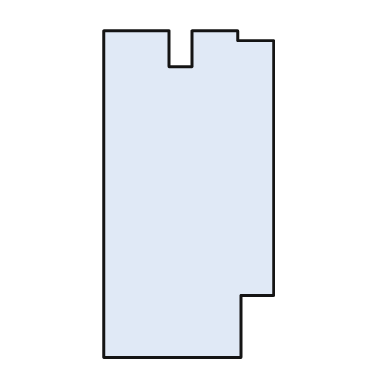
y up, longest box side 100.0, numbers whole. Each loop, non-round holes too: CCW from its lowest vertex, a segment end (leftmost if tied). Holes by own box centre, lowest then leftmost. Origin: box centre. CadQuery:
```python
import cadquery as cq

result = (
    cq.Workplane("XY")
    .moveTo(-26.0, -50.0)
    .lineTo(16.0, -50.0)
    .lineTo(16.0, -31.0)
    .lineTo(26.0, -31.0)
    .lineTo(26.0, 47.0)
    .lineTo(15.0, 47.0)
    .lineTo(15.0, 50.0)
    .lineTo(1.0, 50.0)
    .lineTo(1.0, 39.0)
    .lineTo(-6.0, 39.0)
    .lineTo(-6.0, 50.0)
    .lineTo(-26.0, 50.0)
    .close()
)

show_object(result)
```